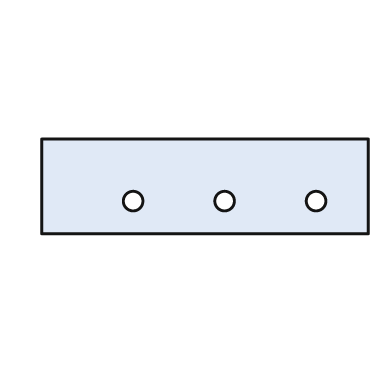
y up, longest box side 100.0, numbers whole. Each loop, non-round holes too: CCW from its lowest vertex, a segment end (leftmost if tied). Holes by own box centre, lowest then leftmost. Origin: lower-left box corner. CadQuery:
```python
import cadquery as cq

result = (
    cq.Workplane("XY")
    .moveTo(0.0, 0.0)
    .lineTo(100.0, 0.0)
    .lineTo(100.0, 29.0)
    .lineTo(0.0, 29.0)
    .close()
    .moveTo(28.0, 10.0)
    .circle(3.0)
    .moveTo(56.0, 10.0)
    .circle(3.0)
    .moveTo(84.0, 10.0)
    .circle(3.0)
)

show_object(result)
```